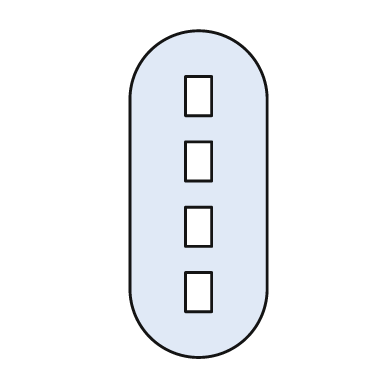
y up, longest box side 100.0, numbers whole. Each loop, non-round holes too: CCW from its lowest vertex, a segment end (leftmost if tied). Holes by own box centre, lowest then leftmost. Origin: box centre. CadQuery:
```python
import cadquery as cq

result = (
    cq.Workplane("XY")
    .moveTo(-21.0, -29.0)
    .threePointArc((0.0, -50.0), (21.0, -29.0))
    .lineTo(21.0, 29.0)
    .threePointArc((0.0, 50.0), (-21.0, 29.0))
    .close()
    .moveTo(-4.0, -36.0)
    .lineTo(4.0, -36.0)
    .lineTo(4.0, -24.0)
    .lineTo(-4.0, -24.0)
    .close()
    .moveTo(-4.0, -16.0)
    .lineTo(4.0, -16.0)
    .lineTo(4.0, -4.0)
    .lineTo(-4.0, -4.0)
    .close()
    .moveTo(-4.0, 4.0)
    .lineTo(4.0, 4.0)
    .lineTo(4.0, 16.0)
    .lineTo(-4.0, 16.0)
    .close()
    .moveTo(-4.0, 24.0)
    .lineTo(4.0, 24.0)
    .lineTo(4.0, 36.0)
    .lineTo(-4.0, 36.0)
    .close()
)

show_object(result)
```